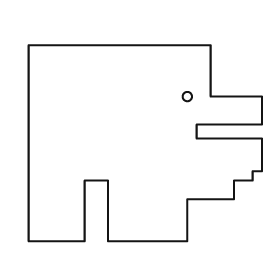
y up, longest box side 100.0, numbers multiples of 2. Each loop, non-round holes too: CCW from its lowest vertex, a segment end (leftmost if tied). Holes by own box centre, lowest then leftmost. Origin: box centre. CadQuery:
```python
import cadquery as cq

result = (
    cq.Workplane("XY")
    .moveTo(-50.0, -42.0)
    .lineTo(-26.0, -42.0)
    .lineTo(-26.0, -16.0)
    .lineTo(-16.0, -16.0)
    .lineTo(-16.0, -42.0)
    .lineTo(18.0, -42.0)
    .lineTo(18.0, -24.0)
    .lineTo(38.0, -24.0)
    .lineTo(38.0, -16.0)
    .lineTo(46.0, -16.0)
    .lineTo(46.0, -12.0)
    .lineTo(50.0, -12.0)
    .lineTo(50.0, 2.0)
    .lineTo(22.0, 2.0)
    .lineTo(22.0, 8.0)
    .lineTo(50.0, 8.0)
    .lineTo(50.0, 20.0)
    .lineTo(28.0, 20.0)
    .lineTo(28.0, 42.0)
    .lineTo(-50.0, 42.0)
    .close()
    .moveTo(18.0, 20.0)
    .circle(2.0)
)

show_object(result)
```